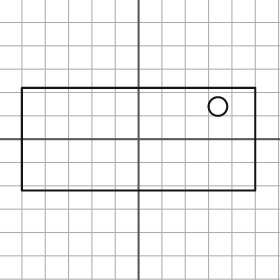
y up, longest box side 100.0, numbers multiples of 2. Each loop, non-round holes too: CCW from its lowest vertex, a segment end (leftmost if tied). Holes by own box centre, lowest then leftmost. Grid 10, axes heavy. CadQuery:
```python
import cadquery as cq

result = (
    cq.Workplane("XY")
    .moveTo(-50.0, -22.0)
    .lineTo(50.0, -22.0)
    .lineTo(50.0, 22.0)
    .lineTo(-50.0, 22.0)
    .close()
    .moveTo(34.0, 14.0)
    .circle(4.0)
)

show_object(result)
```